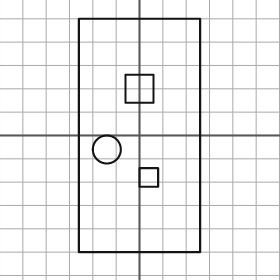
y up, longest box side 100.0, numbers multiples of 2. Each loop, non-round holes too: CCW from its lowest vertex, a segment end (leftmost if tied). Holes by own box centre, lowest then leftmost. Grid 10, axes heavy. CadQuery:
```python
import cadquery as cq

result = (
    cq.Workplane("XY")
    .moveTo(-26.0, -50.0)
    .lineTo(26.0, -50.0)
    .lineTo(26.0, 50.0)
    .lineTo(-26.0, 50.0)
    .close()
    .moveTo(0.0, -22.0)
    .lineTo(8.0, -22.0)
    .lineTo(8.0, -14.0)
    .lineTo(0.0, -14.0)
    .close()
    .moveTo(-14.0, -6.0)
    .circle(6.0)
    .moveTo(-6.0, 14.0)
    .lineTo(6.0, 14.0)
    .lineTo(6.0, 26.0)
    .lineTo(-6.0, 26.0)
    .close()
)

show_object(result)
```